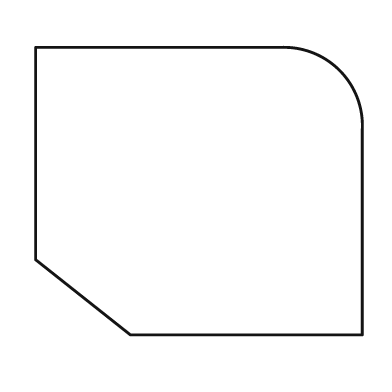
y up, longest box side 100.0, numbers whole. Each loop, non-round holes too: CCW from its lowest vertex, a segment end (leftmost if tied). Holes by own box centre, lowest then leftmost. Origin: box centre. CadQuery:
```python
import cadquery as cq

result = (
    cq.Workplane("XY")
    .moveTo(-21.0, -44.0)
    .lineTo(50.0, -44.0)
    .lineTo(50.0, 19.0)
    .threePointArc((43.0, 37.0), (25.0, 44.0))
    .lineTo(-50.0, 44.0)
    .lineTo(-50.0, -21.0)
    .close()
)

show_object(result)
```